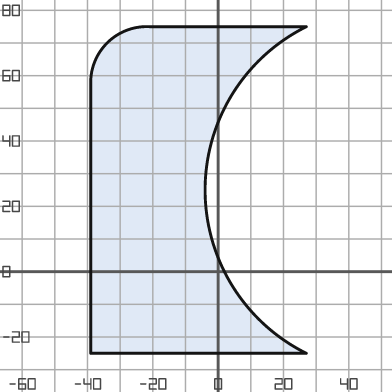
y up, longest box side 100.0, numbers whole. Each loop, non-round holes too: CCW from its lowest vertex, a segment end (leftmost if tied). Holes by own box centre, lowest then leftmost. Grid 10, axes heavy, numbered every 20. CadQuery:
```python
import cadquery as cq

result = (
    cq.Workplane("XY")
    .moveTo(-39.0, -25.0)
    .lineTo(27.0, -25.0)
    .threePointArc((-4.0, 25.0), (27.0, 75.0))
    .lineTo(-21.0, 75.0)
    .threePointArc((-34.0, 70.0), (-39.0, 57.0))
    .close()
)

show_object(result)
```